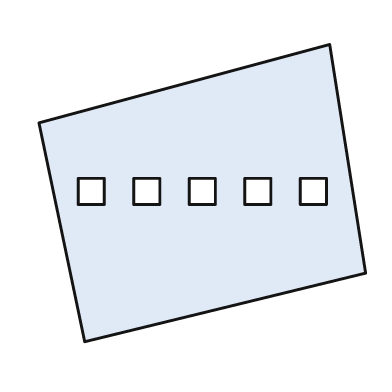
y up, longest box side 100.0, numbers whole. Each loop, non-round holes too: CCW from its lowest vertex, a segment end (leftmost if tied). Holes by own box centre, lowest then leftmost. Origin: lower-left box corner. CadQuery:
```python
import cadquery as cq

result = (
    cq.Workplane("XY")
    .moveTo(14.0, 0.0)
    .lineTo(100.0, 21.0)
    .lineTo(89.0, 91.0)
    .lineTo(0.0, 67.0)
    .close()
    .moveTo(12.0, 42.0)
    .lineTo(20.0, 42.0)
    .lineTo(20.0, 50.0)
    .lineTo(12.0, 50.0)
    .close()
    .moveTo(29.0, 42.0)
    .lineTo(37.0, 42.0)
    .lineTo(37.0, 50.0)
    .lineTo(29.0, 50.0)
    .close()
    .moveTo(46.0, 42.0)
    .lineTo(54.0, 42.0)
    .lineTo(54.0, 50.0)
    .lineTo(46.0, 50.0)
    .close()
    .moveTo(63.0, 42.0)
    .lineTo(71.0, 42.0)
    .lineTo(71.0, 50.0)
    .lineTo(63.0, 50.0)
    .close()
    .moveTo(80.0, 42.0)
    .lineTo(88.0, 42.0)
    .lineTo(88.0, 50.0)
    .lineTo(80.0, 50.0)
    .close()
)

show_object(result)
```